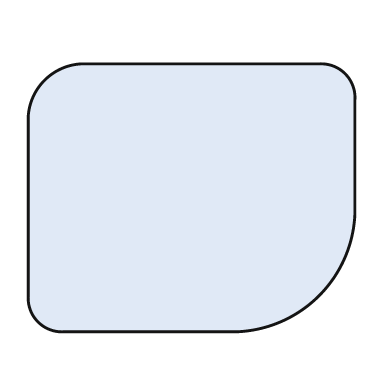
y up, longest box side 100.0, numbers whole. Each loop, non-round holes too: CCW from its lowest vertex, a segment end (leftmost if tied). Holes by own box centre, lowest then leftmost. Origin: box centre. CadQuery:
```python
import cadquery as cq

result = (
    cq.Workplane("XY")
    .moveTo(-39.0, -41.0)
    .lineTo(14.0, -41.0)
    .threePointArc((39.0, -30.0), (50.0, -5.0))
    .lineTo(50.0, 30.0)
    .threePointArc((47.0, 38.0), (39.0, 41.0))
    .lineTo(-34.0, 41.0)
    .threePointArc((-45.0, 36.0), (-50.0, 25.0))
    .lineTo(-50.0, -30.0)
    .threePointArc((-47.0, -38.0), (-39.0, -41.0))
    .close()
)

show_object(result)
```